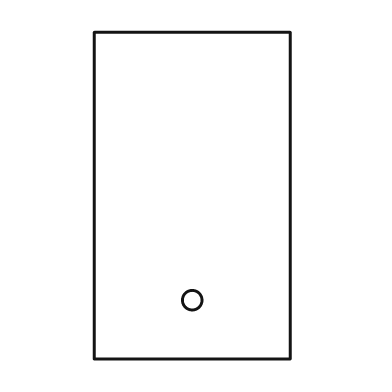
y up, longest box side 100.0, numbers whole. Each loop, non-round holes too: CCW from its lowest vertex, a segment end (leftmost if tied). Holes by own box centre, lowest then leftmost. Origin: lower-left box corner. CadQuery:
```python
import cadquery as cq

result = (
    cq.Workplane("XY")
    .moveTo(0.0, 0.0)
    .lineTo(60.0, 0.0)
    .lineTo(60.0, 100.0)
    .lineTo(0.0, 100.0)
    .close()
    .moveTo(30.0, 18.0)
    .circle(3.0)
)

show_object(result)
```